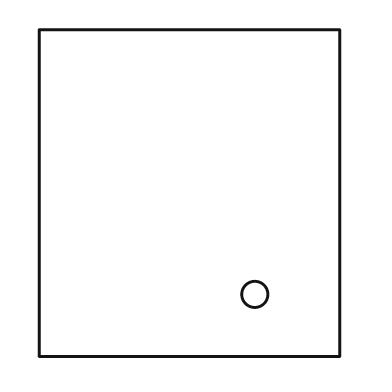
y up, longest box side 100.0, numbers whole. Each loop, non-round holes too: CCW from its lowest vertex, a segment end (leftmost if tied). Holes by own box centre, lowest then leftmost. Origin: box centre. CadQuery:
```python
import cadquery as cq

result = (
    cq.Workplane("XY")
    .moveTo(-46.0, -50.0)
    .lineTo(46.0, -50.0)
    .lineTo(46.0, 50.0)
    .lineTo(-46.0, 50.0)
    .close()
    .moveTo(20.0, -31.0)
    .circle(4.0)
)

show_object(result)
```